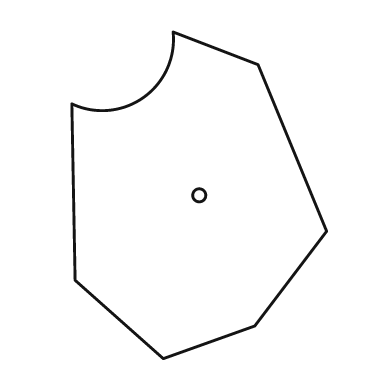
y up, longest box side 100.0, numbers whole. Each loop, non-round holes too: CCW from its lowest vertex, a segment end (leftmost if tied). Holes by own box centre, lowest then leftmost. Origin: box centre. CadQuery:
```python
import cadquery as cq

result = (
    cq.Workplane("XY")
    .moveTo(-11.0, -50.0)
    .lineTo(17.0, -40.0)
    .lineTo(39.0, -11.0)
    .lineTo(18.0, 40.0)
    .lineTo(-8.0, 50.0)
    .threePointArc((-17.0, 30.0), (-39.0, 28.0))
    .lineTo(-38.0, -26.0)
    .close()
    .moveTo(0.0, 0.0)
    .circle(2.0)
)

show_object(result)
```